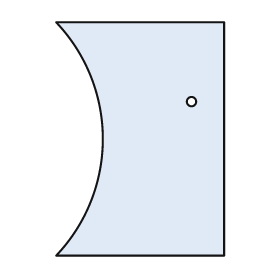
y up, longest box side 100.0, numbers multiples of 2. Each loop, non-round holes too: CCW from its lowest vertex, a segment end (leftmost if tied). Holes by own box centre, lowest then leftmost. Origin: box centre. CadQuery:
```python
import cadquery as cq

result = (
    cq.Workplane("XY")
    .moveTo(-36.0, -50.0)
    .lineTo(36.0, -50.0)
    .lineTo(36.0, 50.0)
    .lineTo(-36.0, 50.0)
    .threePointArc((-16.0, 0.0), (-36.0, -50.0))
    .close()
    .moveTo(22.0, 16.0)
    .circle(2.0)
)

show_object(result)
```